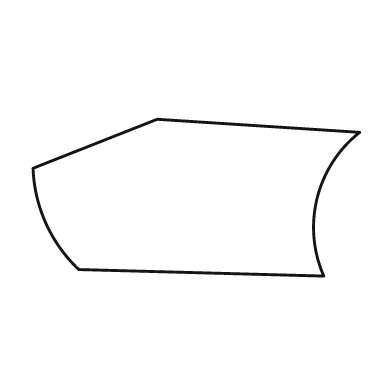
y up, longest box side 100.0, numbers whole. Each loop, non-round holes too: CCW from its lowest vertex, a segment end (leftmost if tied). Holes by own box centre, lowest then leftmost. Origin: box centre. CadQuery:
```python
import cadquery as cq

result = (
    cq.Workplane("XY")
    .moveTo(39.0, -24.0)
    .threePointArc((37.0, 0.0), (50.0, 20.0))
    .lineTo(-12.0, 24.0)
    .lineTo(-50.0, 9.0)
    .threePointArc((-46.0, -8.0), (-36.0, -22.0))
    .close()
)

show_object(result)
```